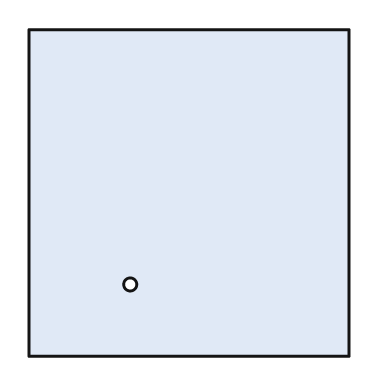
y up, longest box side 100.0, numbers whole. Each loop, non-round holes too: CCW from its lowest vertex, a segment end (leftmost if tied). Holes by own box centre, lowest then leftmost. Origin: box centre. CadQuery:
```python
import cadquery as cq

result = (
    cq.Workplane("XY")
    .moveTo(-49.0, -50.0)
    .lineTo(49.0, -50.0)
    .lineTo(49.0, 50.0)
    .lineTo(-49.0, 50.0)
    .close()
    .moveTo(-18.0, -28.0)
    .circle(2.0)
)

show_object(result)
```